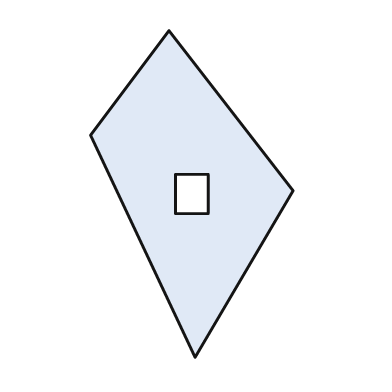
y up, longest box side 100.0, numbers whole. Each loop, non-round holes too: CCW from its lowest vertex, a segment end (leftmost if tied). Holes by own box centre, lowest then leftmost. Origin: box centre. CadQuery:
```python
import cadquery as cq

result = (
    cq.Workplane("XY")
    .moveTo(1.0, -50.0)
    .lineTo(31.0, 1.0)
    .lineTo(-7.0, 50.0)
    .lineTo(-31.0, 18.0)
    .close()
    .moveTo(-5.0, -6.0)
    .lineTo(5.0, -6.0)
    .lineTo(5.0, 6.0)
    .lineTo(-5.0, 6.0)
    .close()
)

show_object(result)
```